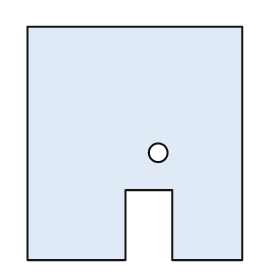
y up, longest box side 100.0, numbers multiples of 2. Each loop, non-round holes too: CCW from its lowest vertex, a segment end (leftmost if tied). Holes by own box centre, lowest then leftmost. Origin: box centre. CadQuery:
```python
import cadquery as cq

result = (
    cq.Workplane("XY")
    .moveTo(-46.0, -50.0)
    .lineTo(-4.0, -50.0)
    .lineTo(-4.0, -20.0)
    .lineTo(16.0, -20.0)
    .lineTo(16.0, -50.0)
    .lineTo(46.0, -50.0)
    .lineTo(46.0, 50.0)
    .lineTo(-46.0, 50.0)
    .close()
    .moveTo(10.0, -4.0)
    .circle(4.0)
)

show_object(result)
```